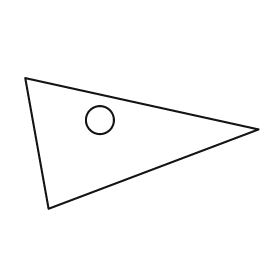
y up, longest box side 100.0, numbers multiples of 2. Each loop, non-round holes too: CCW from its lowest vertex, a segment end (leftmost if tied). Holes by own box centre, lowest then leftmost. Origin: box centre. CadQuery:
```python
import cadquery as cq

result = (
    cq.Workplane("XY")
    .moveTo(-40.0, -28.0)
    .lineTo(50.0, 6.0)
    .lineTo(-50.0, 28.0)
    .close()
    .moveTo(-18.0, 10.0)
    .circle(6.0)
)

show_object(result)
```